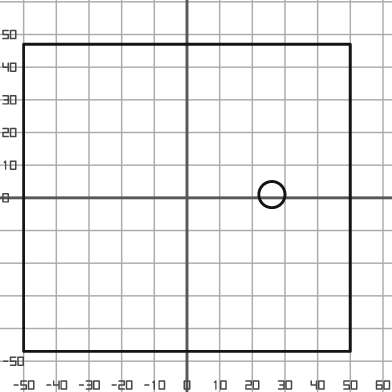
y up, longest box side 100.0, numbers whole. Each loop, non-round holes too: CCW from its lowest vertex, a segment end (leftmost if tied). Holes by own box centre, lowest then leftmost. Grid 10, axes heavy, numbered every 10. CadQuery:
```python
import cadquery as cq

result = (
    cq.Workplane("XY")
    .moveTo(-50.0, -47.0)
    .lineTo(50.0, -47.0)
    .lineTo(50.0, 47.0)
    .lineTo(-50.0, 47.0)
    .close()
    .moveTo(26.0, 1.0)
    .circle(4.0)
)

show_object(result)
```